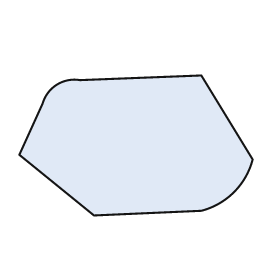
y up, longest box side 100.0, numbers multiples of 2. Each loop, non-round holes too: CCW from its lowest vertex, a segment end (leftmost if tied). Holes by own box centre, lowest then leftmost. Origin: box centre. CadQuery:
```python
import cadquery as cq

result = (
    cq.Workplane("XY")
    .moveTo(-18.0, -30.0)
    .lineTo(28.0, -28.0)
    .threePointArc((42.0, -20.0), (50.0, -6.0))
    .lineTo(28.0, 30.0)
    .lineTo(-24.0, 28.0)
    .threePointArc((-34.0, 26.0), (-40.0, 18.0))
    .lineTo(-50.0, -4.0)
    .close()
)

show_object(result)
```